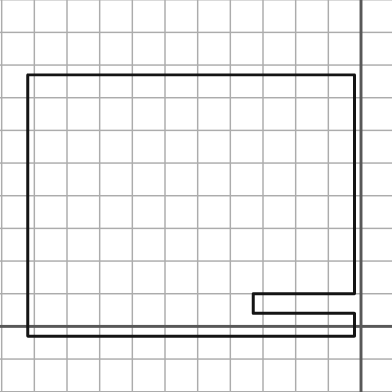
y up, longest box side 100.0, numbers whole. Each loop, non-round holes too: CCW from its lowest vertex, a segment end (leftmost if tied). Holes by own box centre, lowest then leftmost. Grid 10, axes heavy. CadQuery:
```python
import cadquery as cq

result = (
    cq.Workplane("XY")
    .moveTo(-102.0, -3.0)
    .lineTo(-2.0, -3.0)
    .lineTo(-2.0, 4.0)
    .lineTo(-33.0, 4.0)
    .lineTo(-33.0, 10.0)
    .lineTo(-2.0, 10.0)
    .lineTo(-2.0, 77.0)
    .lineTo(-102.0, 77.0)
    .close()
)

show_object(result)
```